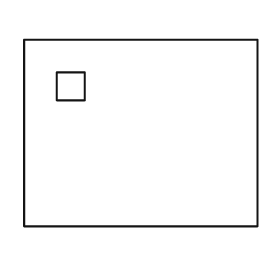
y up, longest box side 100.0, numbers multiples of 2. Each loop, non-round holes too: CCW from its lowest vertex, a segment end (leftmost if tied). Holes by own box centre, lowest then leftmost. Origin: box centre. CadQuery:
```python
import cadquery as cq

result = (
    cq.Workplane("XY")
    .moveTo(-50.0, -40.0)
    .lineTo(50.0, -40.0)
    .lineTo(50.0, 40.0)
    .lineTo(-50.0, 40.0)
    .close()
    .moveTo(-36.0, 14.0)
    .lineTo(-24.0, 14.0)
    .lineTo(-24.0, 26.0)
    .lineTo(-36.0, 26.0)
    .close()
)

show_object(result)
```